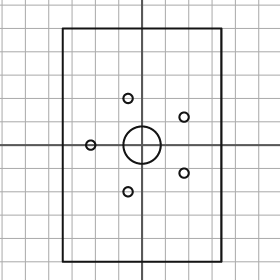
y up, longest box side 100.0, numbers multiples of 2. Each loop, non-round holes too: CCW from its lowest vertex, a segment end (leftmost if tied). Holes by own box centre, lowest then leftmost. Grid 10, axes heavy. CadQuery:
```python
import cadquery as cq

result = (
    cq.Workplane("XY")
    .moveTo(-34.0, -50.0)
    .lineTo(34.0, -50.0)
    .lineTo(34.0, 50.0)
    .lineTo(-34.0, 50.0)
    .close()
    .moveTo(-6.0, -20.0)
    .circle(2.0)
    .moveTo(18.0, -12.0)
    .circle(2.0)
    .moveTo(-22.0, 0.0)
    .circle(2.0)
    .moveTo(0.0, 0.0)
    .circle(8.0)
    .moveTo(18.0, 12.0)
    .circle(2.0)
    .moveTo(-6.0, 20.0)
    .circle(2.0)
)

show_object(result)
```